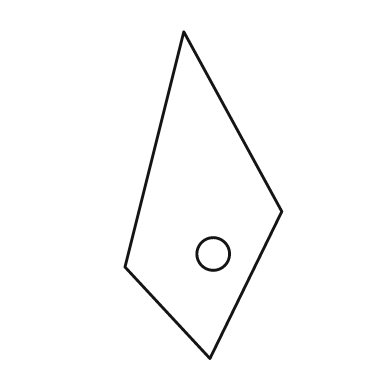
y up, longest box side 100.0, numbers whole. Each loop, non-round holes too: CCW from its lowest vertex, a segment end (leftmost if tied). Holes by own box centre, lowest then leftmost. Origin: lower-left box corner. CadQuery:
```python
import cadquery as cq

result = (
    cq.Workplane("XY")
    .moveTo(26.0, 0.0)
    .lineTo(48.0, 45.0)
    .lineTo(18.0, 100.0)
    .lineTo(0.0, 28.0)
    .close()
    .moveTo(27.0, 32.0)
    .circle(5.0)
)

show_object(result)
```